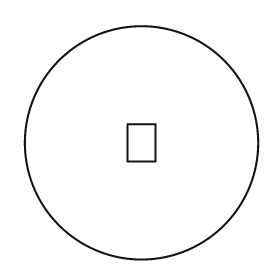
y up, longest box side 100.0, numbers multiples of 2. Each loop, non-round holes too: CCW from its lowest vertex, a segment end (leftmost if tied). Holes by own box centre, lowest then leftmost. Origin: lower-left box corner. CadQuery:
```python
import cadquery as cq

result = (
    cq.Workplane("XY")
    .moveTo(50.0, 50.0)
    .circle(50.0)
    .moveTo(44.0, 42.0)
    .lineTo(56.0, 42.0)
    .lineTo(56.0, 58.0)
    .lineTo(44.0, 58.0)
    .close()
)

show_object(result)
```